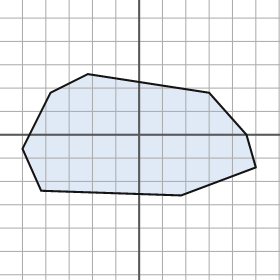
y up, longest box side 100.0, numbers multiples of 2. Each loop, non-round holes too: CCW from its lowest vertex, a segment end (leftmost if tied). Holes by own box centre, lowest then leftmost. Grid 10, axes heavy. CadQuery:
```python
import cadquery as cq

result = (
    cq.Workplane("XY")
    .moveTo(18.0, -26.0)
    .lineTo(50.0, -14.0)
    .lineTo(46.0, 0.0)
    .lineTo(30.0, 18.0)
    .lineTo(-22.0, 26.0)
    .lineTo(-38.0, 18.0)
    .lineTo(-50.0, -6.0)
    .lineTo(-42.0, -24.0)
    .close()
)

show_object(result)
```